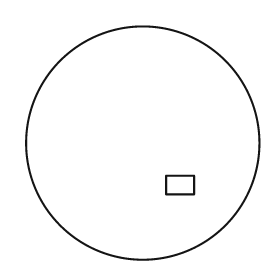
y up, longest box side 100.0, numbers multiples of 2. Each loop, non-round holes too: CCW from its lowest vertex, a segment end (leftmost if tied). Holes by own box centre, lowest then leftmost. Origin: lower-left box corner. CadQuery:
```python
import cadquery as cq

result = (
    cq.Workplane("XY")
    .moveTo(50.0, 50.0)
    .circle(50.0)
    .moveTo(60.0, 28.0)
    .lineTo(72.0, 28.0)
    .lineTo(72.0, 36.0)
    .lineTo(60.0, 36.0)
    .close()
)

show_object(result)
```